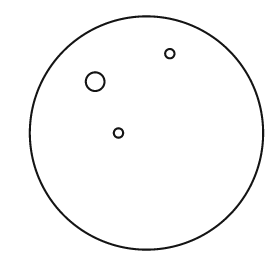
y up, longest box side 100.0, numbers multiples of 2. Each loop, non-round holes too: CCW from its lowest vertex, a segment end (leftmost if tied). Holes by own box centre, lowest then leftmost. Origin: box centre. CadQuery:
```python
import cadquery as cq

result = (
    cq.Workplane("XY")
    .moveTo(0.0, 0.0)
    .circle(50.0)
    .moveTo(-12.0, 0.0)
    .circle(2.0)
    .moveTo(-22.0, 22.0)
    .circle(4.0)
    .moveTo(10.0, 34.0)
    .circle(2.0)
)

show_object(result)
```